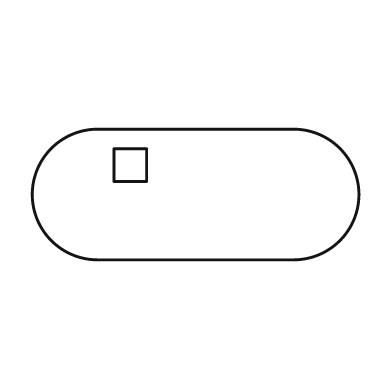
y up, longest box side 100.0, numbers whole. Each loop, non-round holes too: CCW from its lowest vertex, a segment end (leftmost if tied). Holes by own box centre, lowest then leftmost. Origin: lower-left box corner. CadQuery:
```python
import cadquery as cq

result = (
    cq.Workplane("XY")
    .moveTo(20.0, 0.0)
    .lineTo(80.0, 0.0)
    .threePointArc((100.0, 20.0), (80.0, 40.0))
    .lineTo(20.0, 40.0)
    .threePointArc((0.0, 20.0), (20.0, 0.0))
    .close()
    .moveTo(25.0, 24.0)
    .lineTo(35.0, 24.0)
    .lineTo(35.0, 34.0)
    .lineTo(25.0, 34.0)
    .close()
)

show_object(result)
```